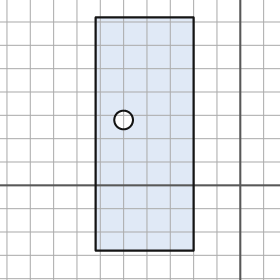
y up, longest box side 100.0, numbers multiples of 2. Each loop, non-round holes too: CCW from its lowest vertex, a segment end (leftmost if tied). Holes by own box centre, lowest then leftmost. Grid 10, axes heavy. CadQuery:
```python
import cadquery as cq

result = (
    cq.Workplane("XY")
    .moveTo(-62.0, -28.0)
    .lineTo(-20.0, -28.0)
    .lineTo(-20.0, 72.0)
    .lineTo(-62.0, 72.0)
    .close()
    .moveTo(-50.0, 28.0)
    .circle(4.0)
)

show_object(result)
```